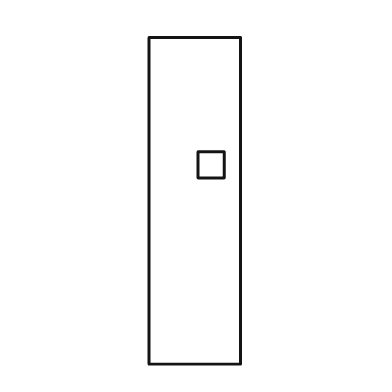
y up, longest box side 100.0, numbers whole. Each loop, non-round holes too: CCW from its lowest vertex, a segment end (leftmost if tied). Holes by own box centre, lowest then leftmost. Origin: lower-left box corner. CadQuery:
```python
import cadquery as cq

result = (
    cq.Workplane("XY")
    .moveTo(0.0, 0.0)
    .lineTo(28.0, 0.0)
    .lineTo(28.0, 100.0)
    .lineTo(0.0, 100.0)
    .close()
    .moveTo(15.0, 57.0)
    .lineTo(23.0, 57.0)
    .lineTo(23.0, 65.0)
    .lineTo(15.0, 65.0)
    .close()
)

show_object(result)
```